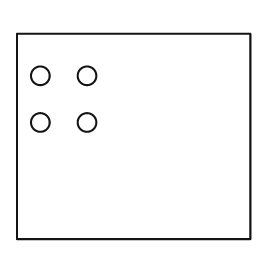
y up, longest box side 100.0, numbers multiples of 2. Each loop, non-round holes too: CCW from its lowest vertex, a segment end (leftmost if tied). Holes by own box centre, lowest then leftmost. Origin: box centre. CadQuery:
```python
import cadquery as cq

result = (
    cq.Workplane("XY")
    .moveTo(-50.0, -44.0)
    .lineTo(50.0, -44.0)
    .lineTo(50.0, 44.0)
    .lineTo(-50.0, 44.0)
    .close()
    .moveTo(-40.0, 6.0)
    .circle(4.0)
    .moveTo(-20.0, 6.0)
    .circle(4.0)
    .moveTo(-40.0, 26.0)
    .circle(4.0)
    .moveTo(-20.0, 26.0)
    .circle(4.0)
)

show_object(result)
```